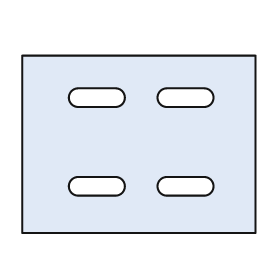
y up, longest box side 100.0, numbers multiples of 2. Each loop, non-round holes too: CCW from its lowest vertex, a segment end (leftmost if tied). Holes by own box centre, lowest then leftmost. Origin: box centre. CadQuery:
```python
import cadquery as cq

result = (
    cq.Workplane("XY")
    .moveTo(-50.0, -38.0)
    .lineTo(50.0, -38.0)
    .lineTo(50.0, 38.0)
    .lineTo(-50.0, 38.0)
    .close()
    .moveTo(-26.0, -22.0)
    .lineTo(-10.0, -22.0)
    .threePointArc((-6.0, -18.0), (-10.0, -14.0))
    .lineTo(-26.0, -14.0)
    .threePointArc((-30.0, -18.0), (-26.0, -22.0))
    .close()
    .moveTo(12.0, -22.0)
    .lineTo(28.0, -22.0)
    .threePointArc((32.0, -18.0), (28.0, -14.0))
    .lineTo(12.0, -14.0)
    .threePointArc((8.0, -18.0), (12.0, -22.0))
    .close()
    .moveTo(-26.0, 16.0)
    .lineTo(-10.0, 16.0)
    .threePointArc((-6.0, 20.0), (-10.0, 24.0))
    .lineTo(-26.0, 24.0)
    .threePointArc((-30.0, 20.0), (-26.0, 16.0))
    .close()
    .moveTo(12.0, 16.0)
    .lineTo(28.0, 16.0)
    .threePointArc((32.0, 20.0), (28.0, 24.0))
    .lineTo(12.0, 24.0)
    .threePointArc((8.0, 20.0), (12.0, 16.0))
    .close()
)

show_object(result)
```